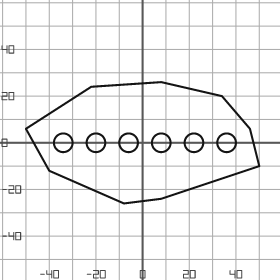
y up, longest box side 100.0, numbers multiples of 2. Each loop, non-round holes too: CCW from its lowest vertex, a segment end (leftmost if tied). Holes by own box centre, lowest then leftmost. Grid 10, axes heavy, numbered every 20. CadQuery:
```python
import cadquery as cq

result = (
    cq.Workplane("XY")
    .moveTo(-8.0, -26.0)
    .lineTo(8.0, -24.0)
    .lineTo(50.0, -10.0)
    .lineTo(46.0, 6.0)
    .lineTo(34.0, 20.0)
    .lineTo(8.0, 26.0)
    .lineTo(-22.0, 24.0)
    .lineTo(-50.0, 6.0)
    .lineTo(-40.0, -12.0)
    .close()
    .moveTo(-34.0, 0.0)
    .circle(4.0)
    .moveTo(-20.0, 0.0)
    .circle(4.0)
    .moveTo(-6.0, 0.0)
    .circle(4.0)
    .moveTo(8.0, 0.0)
    .circle(4.0)
    .moveTo(22.0, 0.0)
    .circle(4.0)
    .moveTo(36.0, 0.0)
    .circle(4.0)
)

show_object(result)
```